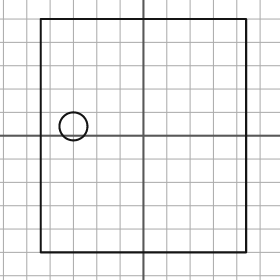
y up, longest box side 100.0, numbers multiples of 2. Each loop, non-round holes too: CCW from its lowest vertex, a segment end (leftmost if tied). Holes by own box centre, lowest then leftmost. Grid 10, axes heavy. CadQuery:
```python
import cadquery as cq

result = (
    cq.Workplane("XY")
    .moveTo(-44.0, -50.0)
    .lineTo(44.0, -50.0)
    .lineTo(44.0, 50.0)
    .lineTo(-44.0, 50.0)
    .close()
    .moveTo(-30.0, 4.0)
    .circle(6.0)
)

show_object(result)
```